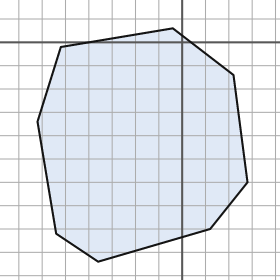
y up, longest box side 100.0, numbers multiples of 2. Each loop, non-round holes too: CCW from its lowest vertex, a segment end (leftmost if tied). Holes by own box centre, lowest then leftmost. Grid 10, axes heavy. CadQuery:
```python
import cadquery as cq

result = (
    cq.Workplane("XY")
    .moveTo(-36.0, -94.0)
    .lineTo(12.0, -80.0)
    .lineTo(28.0, -60.0)
    .lineTo(22.0, -14.0)
    .lineTo(-4.0, 6.0)
    .lineTo(-52.0, -2.0)
    .lineTo(-62.0, -34.0)
    .lineTo(-54.0, -82.0)
    .close()
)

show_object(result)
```